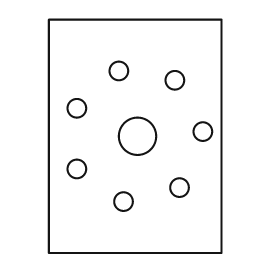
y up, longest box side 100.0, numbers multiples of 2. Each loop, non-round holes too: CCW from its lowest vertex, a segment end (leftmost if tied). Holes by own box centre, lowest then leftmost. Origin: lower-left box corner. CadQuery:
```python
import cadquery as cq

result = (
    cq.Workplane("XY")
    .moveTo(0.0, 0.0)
    .lineTo(74.0, 0.0)
    .lineTo(74.0, 100.0)
    .lineTo(0.0, 100.0)
    .close()
    .moveTo(32.0, 22.0)
    .circle(4.0)
    .moveTo(56.0, 28.0)
    .circle(4.0)
    .moveTo(12.0, 36.0)
    .circle(4.0)
    .moveTo(38.0, 50.0)
    .circle(8.0)
    .moveTo(66.0, 52.0)
    .circle(4.0)
    .moveTo(12.0, 62.0)
    .circle(4.0)
    .moveTo(54.0, 74.0)
    .circle(4.0)
    .moveTo(30.0, 78.0)
    .circle(4.0)
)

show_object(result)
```